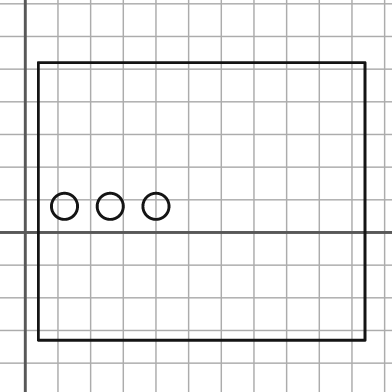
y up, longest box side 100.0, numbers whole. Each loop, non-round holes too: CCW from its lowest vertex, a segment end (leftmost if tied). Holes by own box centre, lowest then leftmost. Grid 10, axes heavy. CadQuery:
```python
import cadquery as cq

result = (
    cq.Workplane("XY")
    .moveTo(4.0, -33.0)
    .lineTo(104.0, -33.0)
    .lineTo(104.0, 52.0)
    .lineTo(4.0, 52.0)
    .close()
    .moveTo(12.0, 8.0)
    .circle(4.0)
    .moveTo(26.0, 8.0)
    .circle(4.0)
    .moveTo(40.0, 8.0)
    .circle(4.0)
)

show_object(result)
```